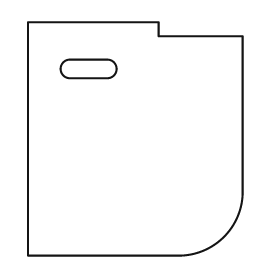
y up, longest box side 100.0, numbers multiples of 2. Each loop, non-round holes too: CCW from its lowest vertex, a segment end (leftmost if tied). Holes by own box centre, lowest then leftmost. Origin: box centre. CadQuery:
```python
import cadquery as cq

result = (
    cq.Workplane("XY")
    .moveTo(-46.0, -50.0)
    .lineTo(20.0, -50.0)
    .threePointArc((38.0, -42.0), (46.0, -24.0))
    .lineTo(46.0, 44.0)
    .lineTo(10.0, 44.0)
    .lineTo(10.0, 50.0)
    .lineTo(-46.0, 50.0)
    .close()
    .moveTo(-28.0, 26.0)
    .lineTo(-12.0, 26.0)
    .threePointArc((-8.0, 30.0), (-12.0, 34.0))
    .lineTo(-28.0, 34.0)
    .threePointArc((-32.0, 30.0), (-28.0, 26.0))
    .close()
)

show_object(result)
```